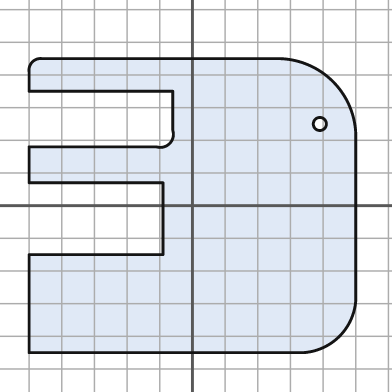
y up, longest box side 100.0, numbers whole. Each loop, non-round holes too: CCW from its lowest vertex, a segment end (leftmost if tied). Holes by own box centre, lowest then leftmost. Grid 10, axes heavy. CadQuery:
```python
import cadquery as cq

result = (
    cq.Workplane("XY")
    .moveTo(-50.0, -45.0)
    .lineTo(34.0, -45.0)
    .threePointArc((45.0, -40.0), (50.0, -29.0))
    .lineTo(50.0, 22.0)
    .threePointArc((43.0, 38.0), (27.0, 45.0))
    .lineTo(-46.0, 45.0)
    .threePointArc((-49.0, 44.0), (-50.0, 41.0))
    .lineTo(-50.0, 35.0)
    .lineTo(-6.0, 35.0)
    .lineTo(-6.0, 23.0)
    .threePointArc((-7.0, 19.0), (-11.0, 18.0))
    .lineTo(-50.0, 18.0)
    .lineTo(-50.0, 7.0)
    .lineTo(-9.0, 7.0)
    .lineTo(-9.0, -15.0)
    .lineTo(-50.0, -15.0)
    .close()
    .moveTo(39.0, 25.0)
    .circle(2.0)
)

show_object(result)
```